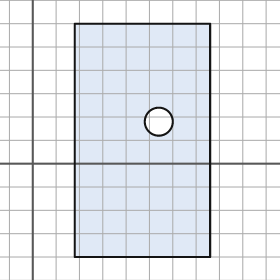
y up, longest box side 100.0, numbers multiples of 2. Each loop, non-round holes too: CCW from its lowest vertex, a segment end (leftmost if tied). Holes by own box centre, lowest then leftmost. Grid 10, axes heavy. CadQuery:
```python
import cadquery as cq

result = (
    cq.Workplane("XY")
    .moveTo(18.0, -40.0)
    .lineTo(76.0, -40.0)
    .lineTo(76.0, 60.0)
    .lineTo(18.0, 60.0)
    .close()
    .moveTo(54.0, 18.0)
    .circle(6.0)
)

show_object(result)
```